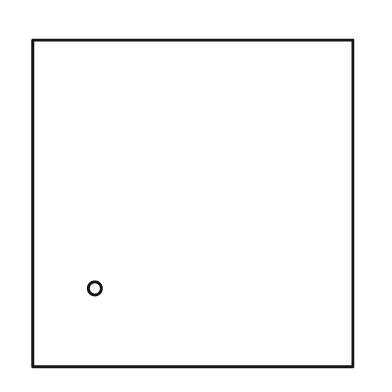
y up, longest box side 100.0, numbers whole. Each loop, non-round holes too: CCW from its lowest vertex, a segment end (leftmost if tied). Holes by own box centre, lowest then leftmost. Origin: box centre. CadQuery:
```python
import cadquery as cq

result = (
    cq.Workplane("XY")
    .moveTo(-49.0, -50.0)
    .lineTo(49.0, -50.0)
    .lineTo(49.0, 50.0)
    .lineTo(-49.0, 50.0)
    .close()
    .moveTo(-30.0, -26.0)
    .circle(2.0)
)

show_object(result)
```